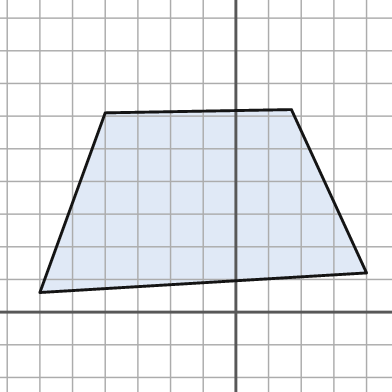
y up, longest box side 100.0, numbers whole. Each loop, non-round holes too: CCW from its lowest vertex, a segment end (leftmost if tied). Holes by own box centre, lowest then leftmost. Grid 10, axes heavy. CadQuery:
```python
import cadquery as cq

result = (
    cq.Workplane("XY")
    .moveTo(-60.0, 6.0)
    .lineTo(40.0, 12.0)
    .lineTo(17.0, 62.0)
    .lineTo(-40.0, 61.0)
    .close()
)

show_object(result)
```